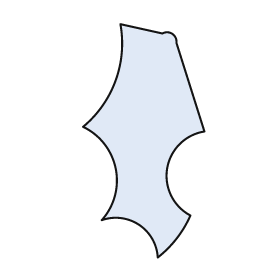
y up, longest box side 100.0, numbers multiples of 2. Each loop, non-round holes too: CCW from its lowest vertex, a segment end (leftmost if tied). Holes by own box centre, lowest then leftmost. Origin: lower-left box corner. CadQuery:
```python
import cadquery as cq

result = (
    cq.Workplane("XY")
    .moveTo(32.0, 0.0)
    .threePointArc((40.0, 8.0), (46.0, 18.0))
    .threePointArc((36.0, 38.0), (52.0, 54.0))
    .lineTo(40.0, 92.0)
    .threePointArc((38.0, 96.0), (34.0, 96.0))
    .lineTo(16.0, 100.0)
    .threePointArc((14.0, 76.0), (0.0, 56.0))
    .threePointArc((14.0, 38.0), (8.0, 16.0))
    .threePointArc((24.0, 14.0), (32.0, 0.0))
    .close()
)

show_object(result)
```